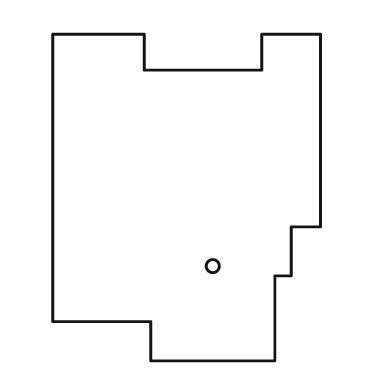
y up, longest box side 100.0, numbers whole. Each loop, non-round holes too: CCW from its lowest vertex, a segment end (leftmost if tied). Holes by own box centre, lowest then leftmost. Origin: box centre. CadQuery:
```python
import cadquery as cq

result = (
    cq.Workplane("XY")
    .moveTo(-11.0, -50.0)
    .lineTo(27.0, -50.0)
    .lineTo(27.0, -24.0)
    .lineTo(32.0, -24.0)
    .lineTo(32.0, -9.0)
    .lineTo(41.0, -9.0)
    .lineTo(41.0, 50.0)
    .lineTo(23.0, 50.0)
    .lineTo(23.0, 39.0)
    .lineTo(-13.0, 39.0)
    .lineTo(-13.0, 50.0)
    .lineTo(-41.0, 50.0)
    .lineTo(-41.0, -38.0)
    .lineTo(-11.0, -38.0)
    .close()
    .moveTo(8.0, -21.0)
    .circle(2.0)
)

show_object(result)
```